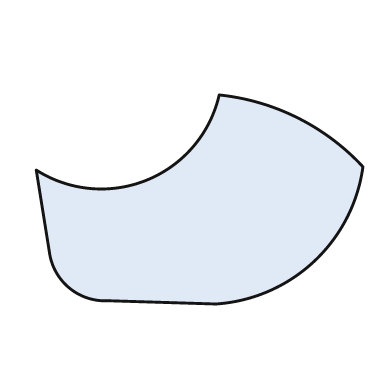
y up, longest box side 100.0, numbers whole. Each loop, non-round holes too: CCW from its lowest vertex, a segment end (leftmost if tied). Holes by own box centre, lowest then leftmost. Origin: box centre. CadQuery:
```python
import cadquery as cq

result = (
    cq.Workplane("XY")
    .moveTo(5.0, -32.0)
    .threePointArc((35.0, -19.0), (50.0, 10.0))
    .threePointArc((30.0, 25.0), (6.0, 32.0))
    .threePointArc((-16.0, 6.0), (-50.0, 9.0))
    .lineTo(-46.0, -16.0)
    .threePointArc((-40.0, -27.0), (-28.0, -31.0))
    .close()
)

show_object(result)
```